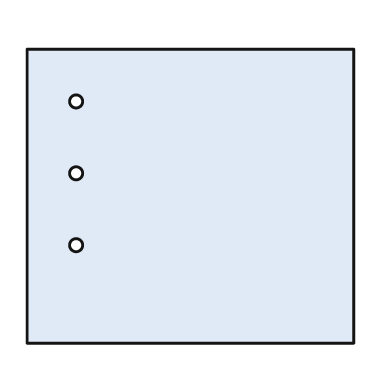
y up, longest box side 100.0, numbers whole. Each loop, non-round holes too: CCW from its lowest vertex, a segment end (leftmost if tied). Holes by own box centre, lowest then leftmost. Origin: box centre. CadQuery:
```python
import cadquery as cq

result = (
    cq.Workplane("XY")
    .moveTo(-50.0, -45.0)
    .lineTo(50.0, -45.0)
    .lineTo(50.0, 45.0)
    .lineTo(-50.0, 45.0)
    .close()
    .moveTo(-35.0, -15.0)
    .circle(2.0)
    .moveTo(-35.0, 7.0)
    .circle(2.0)
    .moveTo(-35.0, 29.0)
    .circle(2.0)
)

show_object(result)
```